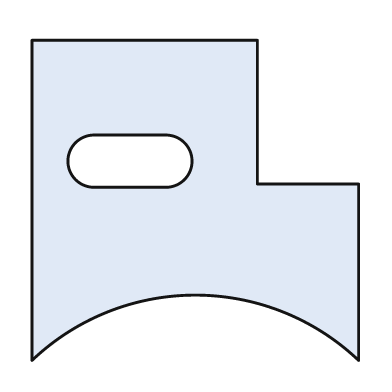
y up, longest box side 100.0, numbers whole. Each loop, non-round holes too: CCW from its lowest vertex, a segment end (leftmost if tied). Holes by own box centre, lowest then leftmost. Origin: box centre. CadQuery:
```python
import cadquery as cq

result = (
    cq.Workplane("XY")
    .moveTo(-50.0, -49.0)
    .threePointArc((0.0, -29.0), (50.0, -49.0))
    .lineTo(50.0, 5.0)
    .lineTo(19.0, 5.0)
    .lineTo(19.0, 49.0)
    .lineTo(-50.0, 49.0)
    .close()
    .moveTo(-31.0, 4.0)
    .lineTo(-9.0, 4.0)
    .threePointArc((-1.0, 12.0), (-9.0, 20.0))
    .lineTo(-31.0, 20.0)
    .threePointArc((-39.0, 12.0), (-31.0, 4.0))
    .close()
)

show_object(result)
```